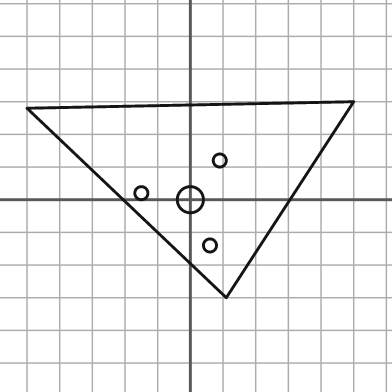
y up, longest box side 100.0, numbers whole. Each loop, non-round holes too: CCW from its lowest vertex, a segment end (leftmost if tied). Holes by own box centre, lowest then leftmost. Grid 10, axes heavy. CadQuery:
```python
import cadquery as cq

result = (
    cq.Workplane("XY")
    .moveTo(11.0, -30.0)
    .lineTo(50.0, 30.0)
    .lineTo(-50.0, 28.0)
    .close()
    .moveTo(6.0, -14.0)
    .circle(2.0)
    .moveTo(0.0, 0.0)
    .circle(4.0)
    .moveTo(-15.0, 2.0)
    .circle(2.0)
    .moveTo(9.0, 12.0)
    .circle(2.0)
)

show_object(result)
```